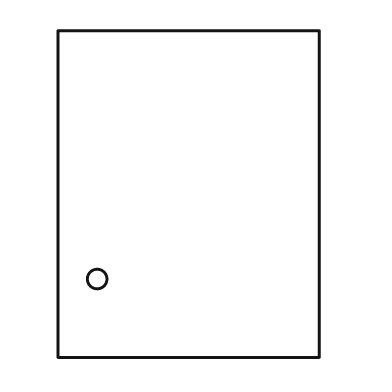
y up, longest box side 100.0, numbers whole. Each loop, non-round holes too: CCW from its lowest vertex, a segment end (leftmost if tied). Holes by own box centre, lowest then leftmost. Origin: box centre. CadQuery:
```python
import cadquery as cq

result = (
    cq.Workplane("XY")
    .moveTo(-40.0, -50.0)
    .lineTo(40.0, -50.0)
    .lineTo(40.0, 50.0)
    .lineTo(-40.0, 50.0)
    .close()
    .moveTo(-28.0, -26.0)
    .circle(3.0)
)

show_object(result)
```